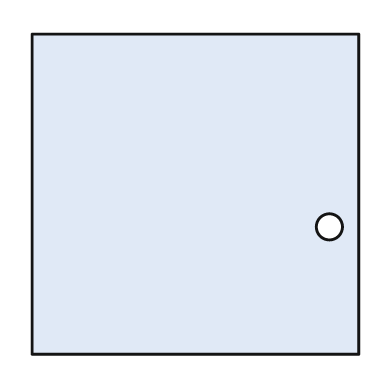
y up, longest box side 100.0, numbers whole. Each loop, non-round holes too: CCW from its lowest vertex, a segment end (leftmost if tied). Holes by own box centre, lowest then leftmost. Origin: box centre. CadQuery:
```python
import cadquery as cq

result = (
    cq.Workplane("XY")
    .moveTo(-50.0, -49.0)
    .lineTo(50.0, -49.0)
    .lineTo(50.0, 49.0)
    .lineTo(-50.0, 49.0)
    .close()
    .moveTo(41.0, -10.0)
    .circle(4.0)
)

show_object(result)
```